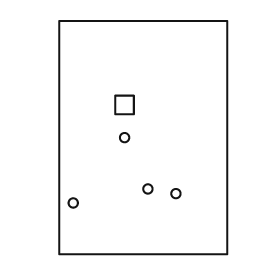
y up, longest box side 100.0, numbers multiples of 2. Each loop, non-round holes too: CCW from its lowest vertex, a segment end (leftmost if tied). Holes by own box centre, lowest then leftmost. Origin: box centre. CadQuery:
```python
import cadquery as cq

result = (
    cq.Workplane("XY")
    .moveTo(-36.0, -50.0)
    .lineTo(36.0, -50.0)
    .lineTo(36.0, 50.0)
    .lineTo(-36.0, 50.0)
    .close()
    .moveTo(-30.0, -28.0)
    .circle(2.0)
    .moveTo(14.0, -24.0)
    .circle(2.0)
    .moveTo(2.0, -22.0)
    .circle(2.0)
    .moveTo(-8.0, 0.0)
    .circle(2.0)
    .moveTo(-12.0, 10.0)
    .lineTo(-4.0, 10.0)
    .lineTo(-4.0, 18.0)
    .lineTo(-12.0, 18.0)
    .close()
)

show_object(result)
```